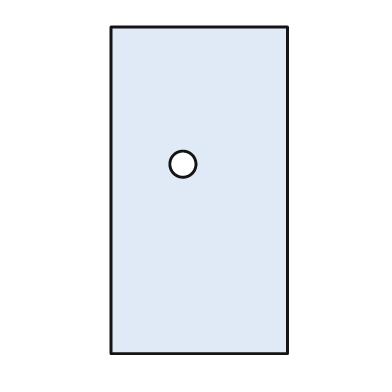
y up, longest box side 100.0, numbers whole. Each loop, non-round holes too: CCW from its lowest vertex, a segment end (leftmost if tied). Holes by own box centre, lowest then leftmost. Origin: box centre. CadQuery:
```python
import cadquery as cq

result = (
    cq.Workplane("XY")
    .moveTo(-27.0, -50.0)
    .lineTo(27.0, -50.0)
    .lineTo(27.0, 50.0)
    .lineTo(-27.0, 50.0)
    .close()
    .moveTo(-5.0, 8.0)
    .circle(4.0)
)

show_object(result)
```